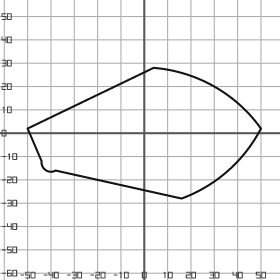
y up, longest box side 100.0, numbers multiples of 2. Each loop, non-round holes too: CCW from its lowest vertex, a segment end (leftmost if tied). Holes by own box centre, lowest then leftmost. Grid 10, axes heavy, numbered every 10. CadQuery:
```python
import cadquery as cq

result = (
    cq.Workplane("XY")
    .moveTo(16.0, -28.0)
    .threePointArc((36.0, -16.0), (50.0, 2.0))
    .threePointArc((30.0, 20.0), (4.0, 28.0))
    .lineTo(-50.0, 2.0)
    .lineTo(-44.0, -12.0)
    .threePointArc((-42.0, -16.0), (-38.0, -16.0))
    .close()
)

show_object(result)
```